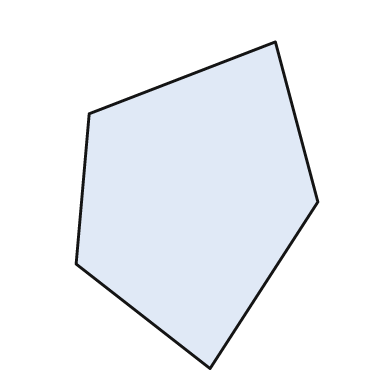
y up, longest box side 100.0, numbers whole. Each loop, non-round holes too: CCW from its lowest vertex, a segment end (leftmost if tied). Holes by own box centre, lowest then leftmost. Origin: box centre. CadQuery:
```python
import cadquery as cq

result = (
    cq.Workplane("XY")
    .moveTo(4.0, -50.0)
    .lineTo(37.0, 1.0)
    .lineTo(24.0, 50.0)
    .lineTo(-33.0, 28.0)
    .lineTo(-37.0, -18.0)
    .close()
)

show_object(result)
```